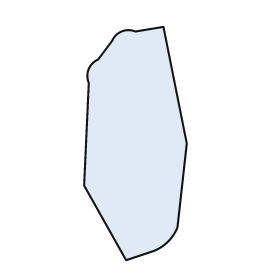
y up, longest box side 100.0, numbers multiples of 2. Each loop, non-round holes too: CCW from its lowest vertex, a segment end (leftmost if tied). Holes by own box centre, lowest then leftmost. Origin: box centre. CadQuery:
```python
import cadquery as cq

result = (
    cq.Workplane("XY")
    .moveTo(-4.0, -50.0)
    .lineTo(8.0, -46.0)
    .threePointArc((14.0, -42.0), (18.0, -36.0))
    .lineTo(22.0, 0.0)
    .lineTo(12.0, 50.0)
    .lineTo(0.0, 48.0)
    .threePointArc((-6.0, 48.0), (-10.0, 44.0))
    .lineTo(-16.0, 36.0)
    .threePointArc((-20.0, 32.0), (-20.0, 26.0))
    .lineTo(-22.0, -18.0)
    .close()
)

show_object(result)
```